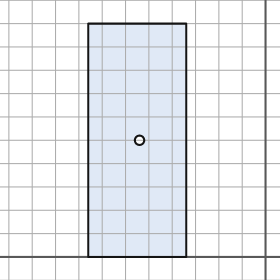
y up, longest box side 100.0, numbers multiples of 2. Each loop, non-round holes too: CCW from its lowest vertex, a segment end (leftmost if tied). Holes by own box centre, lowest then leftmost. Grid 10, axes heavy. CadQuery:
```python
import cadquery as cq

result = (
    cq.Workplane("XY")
    .moveTo(-76.0, 0.0)
    .lineTo(-34.0, 0.0)
    .lineTo(-34.0, 100.0)
    .lineTo(-76.0, 100.0)
    .close()
    .moveTo(-54.0, 50.0)
    .circle(2.0)
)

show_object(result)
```